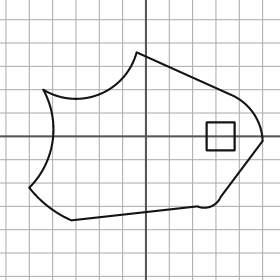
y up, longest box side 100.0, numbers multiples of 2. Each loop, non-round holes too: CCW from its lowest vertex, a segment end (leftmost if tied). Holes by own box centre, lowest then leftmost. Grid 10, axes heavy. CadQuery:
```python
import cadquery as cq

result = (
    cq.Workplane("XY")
    .moveTo(-32.0, -36.0)
    .lineTo(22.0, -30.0)
    .threePointArc((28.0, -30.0), (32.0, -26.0))
    .lineTo(50.0, -2.0)
    .threePointArc((46.0, 10.0), (36.0, 18.0))
    .lineTo(-4.0, 36.0)
    .threePointArc((-20.0, 18.0), (-44.0, 20.0))
    .threePointArc((-40.0, -2.0), (-50.0, -22.0))
    .threePointArc((-42.0, -30.0), (-32.0, -36.0))
    .close()
    .moveTo(26.0, -6.0)
    .lineTo(38.0, -6.0)
    .lineTo(38.0, 6.0)
    .lineTo(26.0, 6.0)
    .close()
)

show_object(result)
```